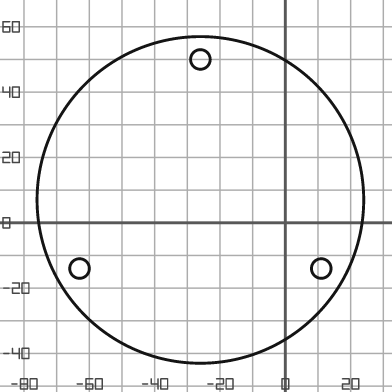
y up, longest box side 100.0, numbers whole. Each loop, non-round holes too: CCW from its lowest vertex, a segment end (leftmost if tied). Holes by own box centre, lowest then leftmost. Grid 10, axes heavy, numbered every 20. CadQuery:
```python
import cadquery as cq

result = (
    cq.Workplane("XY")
    .moveTo(-26.0, 7.0)
    .circle(50.0)
    .moveTo(-63.0, -14.0)
    .circle(3.0)
    .moveTo(11.0, -14.0)
    .circle(3.0)
    .moveTo(-26.0, 50.0)
    .circle(3.0)
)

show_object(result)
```